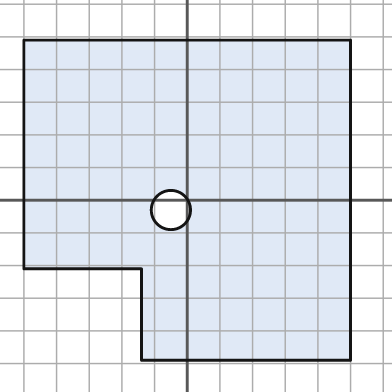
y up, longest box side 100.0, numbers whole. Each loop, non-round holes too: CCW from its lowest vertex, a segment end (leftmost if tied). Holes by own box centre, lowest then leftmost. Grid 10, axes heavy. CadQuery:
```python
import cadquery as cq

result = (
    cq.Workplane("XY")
    .moveTo(-14.0, -49.0)
    .lineTo(50.0, -49.0)
    .lineTo(50.0, 49.0)
    .lineTo(-50.0, 49.0)
    .lineTo(-50.0, -21.0)
    .lineTo(-14.0, -21.0)
    .close()
    .moveTo(-5.0, -3.0)
    .circle(6.0)
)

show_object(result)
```